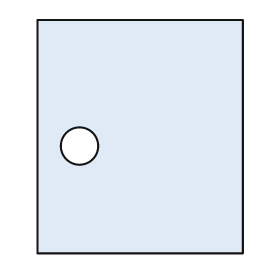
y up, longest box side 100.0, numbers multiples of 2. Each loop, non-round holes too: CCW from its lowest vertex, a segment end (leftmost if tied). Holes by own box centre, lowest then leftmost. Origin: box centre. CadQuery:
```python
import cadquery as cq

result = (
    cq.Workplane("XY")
    .moveTo(-44.0, -50.0)
    .lineTo(44.0, -50.0)
    .lineTo(44.0, 50.0)
    .lineTo(-44.0, 50.0)
    .close()
    .moveTo(-26.0, -4.0)
    .circle(8.0)
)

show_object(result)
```